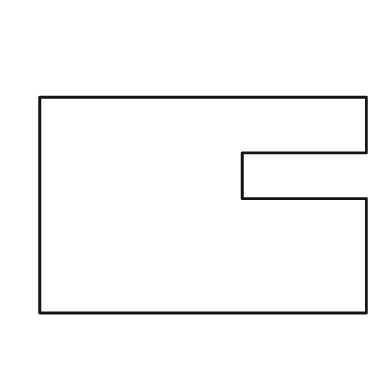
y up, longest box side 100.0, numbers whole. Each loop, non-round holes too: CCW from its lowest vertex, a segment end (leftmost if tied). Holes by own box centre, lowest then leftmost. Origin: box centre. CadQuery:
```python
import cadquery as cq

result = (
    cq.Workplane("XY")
    .moveTo(-50.0, -33.0)
    .lineTo(50.0, -33.0)
    .lineTo(50.0, 2.0)
    .lineTo(12.0, 2.0)
    .lineTo(12.0, 16.0)
    .lineTo(50.0, 16.0)
    .lineTo(50.0, 33.0)
    .lineTo(-50.0, 33.0)
    .close()
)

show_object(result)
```